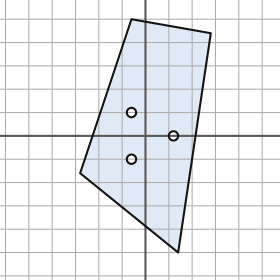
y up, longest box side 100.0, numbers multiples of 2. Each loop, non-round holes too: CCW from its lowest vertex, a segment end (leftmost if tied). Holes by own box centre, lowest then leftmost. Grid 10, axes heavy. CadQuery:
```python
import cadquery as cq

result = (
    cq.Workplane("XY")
    .moveTo(14.0, -50.0)
    .lineTo(28.0, 44.0)
    .lineTo(-6.0, 50.0)
    .lineTo(-28.0, -16.0)
    .close()
    .moveTo(-6.0, -10.0)
    .circle(2.0)
    .moveTo(12.0, 0.0)
    .circle(2.0)
    .moveTo(-6.0, 10.0)
    .circle(2.0)
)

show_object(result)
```